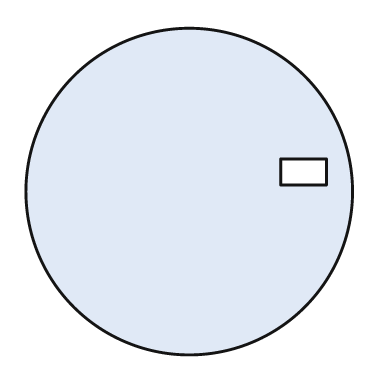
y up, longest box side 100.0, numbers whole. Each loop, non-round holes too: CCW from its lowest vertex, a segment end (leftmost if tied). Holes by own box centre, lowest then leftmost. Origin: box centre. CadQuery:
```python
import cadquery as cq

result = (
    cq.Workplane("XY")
    .moveTo(0.0, 0.0)
    .circle(50.0)
    .moveTo(28.0, 2.0)
    .lineTo(42.0, 2.0)
    .lineTo(42.0, 10.0)
    .lineTo(28.0, 10.0)
    .close()
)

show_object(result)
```